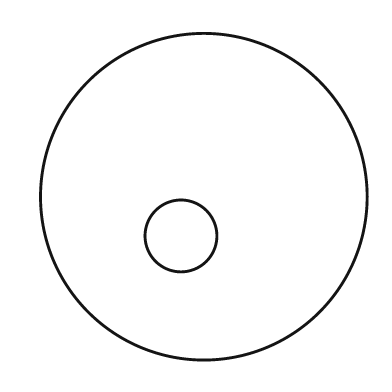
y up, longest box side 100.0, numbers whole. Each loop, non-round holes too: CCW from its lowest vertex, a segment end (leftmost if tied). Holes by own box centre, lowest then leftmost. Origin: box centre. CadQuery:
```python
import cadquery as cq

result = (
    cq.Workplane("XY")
    .moveTo(0.0, 0.0)
    .circle(50.0)
    .moveTo(-7.0, -12.0)
    .circle(11.0)
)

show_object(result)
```